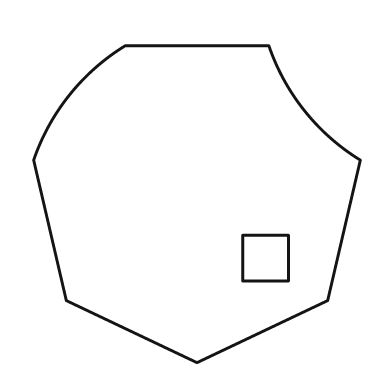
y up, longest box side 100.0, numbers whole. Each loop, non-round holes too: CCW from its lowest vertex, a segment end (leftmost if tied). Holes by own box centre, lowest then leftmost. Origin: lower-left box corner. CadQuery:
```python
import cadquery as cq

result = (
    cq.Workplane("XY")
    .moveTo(50.0, 0.0)
    .lineTo(90.0, 19.0)
    .lineTo(100.0, 62.0)
    .threePointArc((83.0, 77.0), (72.0, 97.0))
    .lineTo(28.0, 97.0)
    .threePointArc((11.0, 82.0), (0.0, 62.0))
    .lineTo(10.0, 19.0)
    .close()
    .moveTo(64.0, 25.0)
    .lineTo(78.0, 25.0)
    .lineTo(78.0, 39.0)
    .lineTo(64.0, 39.0)
    .close()
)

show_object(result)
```